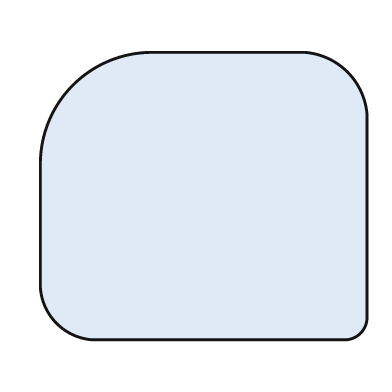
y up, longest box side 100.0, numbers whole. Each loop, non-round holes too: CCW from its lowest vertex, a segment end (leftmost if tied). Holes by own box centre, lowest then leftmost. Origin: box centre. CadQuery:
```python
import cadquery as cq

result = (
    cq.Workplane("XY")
    .moveTo(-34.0, -44.0)
    .lineTo(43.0, -44.0)
    .threePointArc((48.0, -42.0), (50.0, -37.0))
    .lineTo(50.0, 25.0)
    .threePointArc((44.0, 38.0), (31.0, 44.0))
    .lineTo(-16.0, 44.0)
    .threePointArc((-40.0, 34.0), (-50.0, 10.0))
    .lineTo(-50.0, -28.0)
    .threePointArc((-45.0, -39.0), (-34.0, -44.0))
    .close()
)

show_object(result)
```